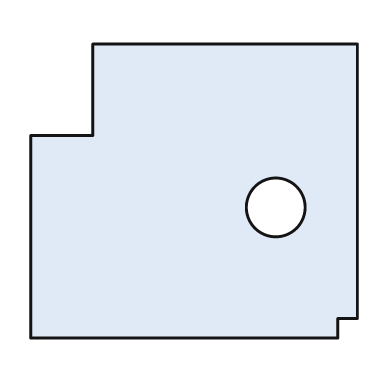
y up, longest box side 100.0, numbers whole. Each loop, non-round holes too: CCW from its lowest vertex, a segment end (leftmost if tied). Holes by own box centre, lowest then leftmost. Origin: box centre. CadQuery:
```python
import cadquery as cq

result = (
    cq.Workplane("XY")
    .moveTo(-50.0, -45.0)
    .lineTo(44.0, -45.0)
    .lineTo(44.0, -39.0)
    .lineTo(50.0, -39.0)
    .lineTo(50.0, 45.0)
    .lineTo(-31.0, 45.0)
    .lineTo(-31.0, 17.0)
    .lineTo(-50.0, 17.0)
    .close()
    .moveTo(25.0, -5.0)
    .circle(9.0)
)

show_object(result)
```